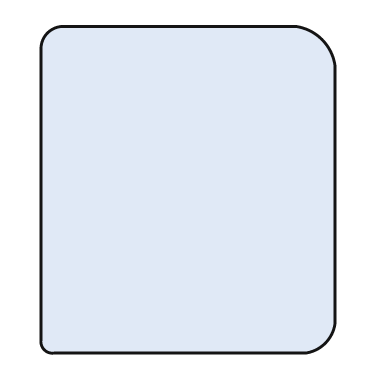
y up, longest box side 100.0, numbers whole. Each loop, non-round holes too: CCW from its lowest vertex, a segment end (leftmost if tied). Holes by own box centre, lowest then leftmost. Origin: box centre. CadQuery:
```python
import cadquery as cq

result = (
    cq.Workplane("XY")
    .moveTo(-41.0, -50.0)
    .lineTo(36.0, -50.0)
    .threePointArc((42.0, -47.0), (45.0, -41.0))
    .lineTo(45.0, 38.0)
    .threePointArc((41.0, 46.0), (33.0, 50.0))
    .lineTo(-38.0, 50.0)
    .threePointArc((-43.0, 48.0), (-45.0, 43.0))
    .lineTo(-45.0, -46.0)
    .threePointArc((-44.0, -49.0), (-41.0, -50.0))
    .close()
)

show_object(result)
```